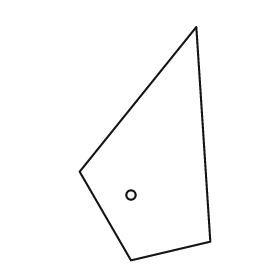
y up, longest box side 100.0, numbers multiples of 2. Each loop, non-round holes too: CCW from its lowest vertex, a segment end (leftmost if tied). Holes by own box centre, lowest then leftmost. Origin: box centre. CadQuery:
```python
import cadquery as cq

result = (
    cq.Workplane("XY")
    .moveTo(-6.0, -50.0)
    .lineTo(28.0, -42.0)
    .lineTo(22.0, 50.0)
    .lineTo(-28.0, -12.0)
    .close()
    .moveTo(-6.0, -22.0)
    .circle(2.0)
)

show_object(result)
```